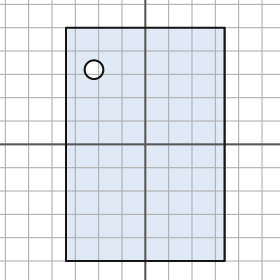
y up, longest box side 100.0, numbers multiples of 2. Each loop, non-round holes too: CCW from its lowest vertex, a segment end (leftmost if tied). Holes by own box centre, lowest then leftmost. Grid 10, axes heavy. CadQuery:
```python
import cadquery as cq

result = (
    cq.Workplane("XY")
    .moveTo(-34.0, -50.0)
    .lineTo(34.0, -50.0)
    .lineTo(34.0, 50.0)
    .lineTo(-34.0, 50.0)
    .close()
    .moveTo(-22.0, 32.0)
    .circle(4.0)
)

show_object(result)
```